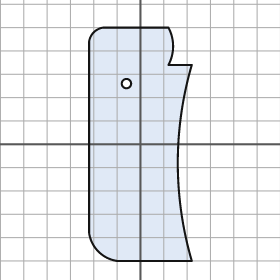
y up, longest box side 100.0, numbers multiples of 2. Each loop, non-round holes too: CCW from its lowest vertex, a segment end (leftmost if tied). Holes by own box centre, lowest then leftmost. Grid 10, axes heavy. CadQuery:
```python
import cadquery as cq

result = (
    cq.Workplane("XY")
    .moveTo(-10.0, -50.0)
    .lineTo(22.0, -50.0)
    .threePointArc((16.0, -8.0), (22.0, 34.0))
    .lineTo(12.0, 34.0)
    .threePointArc((14.0, 42.0), (12.0, 50.0))
    .lineTo(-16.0, 50.0)
    .threePointArc((-20.0, 48.0), (-22.0, 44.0))
    .lineTo(-22.0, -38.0)
    .threePointArc((-18.0, -46.0), (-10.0, -50.0))
    .close()
    .moveTo(-6.0, 26.0)
    .circle(2.0)
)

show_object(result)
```